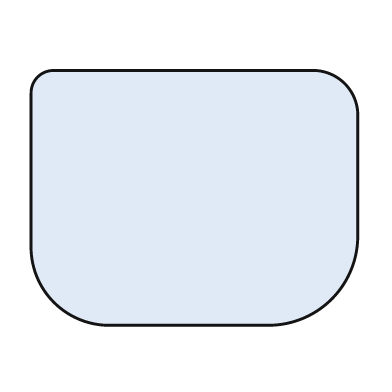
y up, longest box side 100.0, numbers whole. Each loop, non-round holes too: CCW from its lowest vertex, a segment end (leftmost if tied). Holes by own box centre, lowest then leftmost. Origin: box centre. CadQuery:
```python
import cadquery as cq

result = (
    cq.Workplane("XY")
    .moveTo(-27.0, -39.0)
    .lineTo(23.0, -39.0)
    .threePointArc((42.0, -31.0), (50.0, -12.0))
    .lineTo(50.0, 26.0)
    .threePointArc((46.0, 35.0), (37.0, 39.0))
    .lineTo(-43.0, 39.0)
    .threePointArc((-48.0, 37.0), (-50.0, 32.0))
    .lineTo(-50.0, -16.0)
    .threePointArc((-43.0, -32.0), (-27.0, -39.0))
    .close()
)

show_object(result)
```